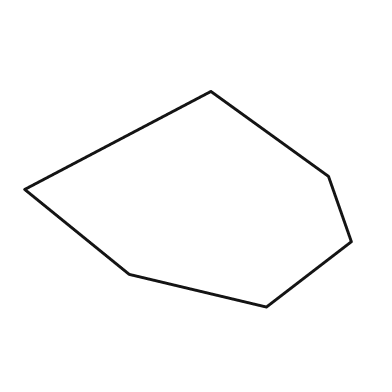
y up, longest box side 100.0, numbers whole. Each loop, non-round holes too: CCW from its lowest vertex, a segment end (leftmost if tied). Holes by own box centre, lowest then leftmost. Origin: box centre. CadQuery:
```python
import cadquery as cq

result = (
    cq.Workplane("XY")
    .moveTo(24.0, -33.0)
    .lineTo(50.0, -13.0)
    .lineTo(43.0, 7.0)
    .lineTo(7.0, 33.0)
    .lineTo(-50.0, 3.0)
    .lineTo(-18.0, -23.0)
    .close()
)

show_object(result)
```